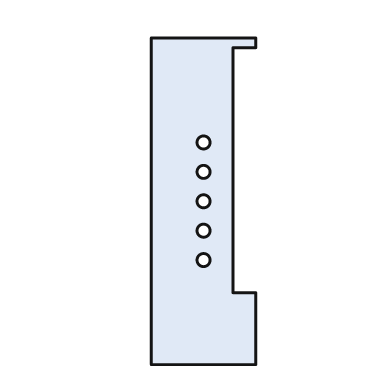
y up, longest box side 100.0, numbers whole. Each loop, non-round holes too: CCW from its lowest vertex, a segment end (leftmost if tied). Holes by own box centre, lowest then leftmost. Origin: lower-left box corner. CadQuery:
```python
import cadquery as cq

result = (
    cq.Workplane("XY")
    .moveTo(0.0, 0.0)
    .lineTo(32.0, 0.0)
    .lineTo(32.0, 22.0)
    .lineTo(25.0, 22.0)
    .lineTo(25.0, 97.0)
    .lineTo(32.0, 97.0)
    .lineTo(32.0, 100.0)
    .lineTo(0.0, 100.0)
    .close()
    .moveTo(16.0, 32.0)
    .circle(2.0)
    .moveTo(16.0, 41.0)
    .circle(2.0)
    .moveTo(16.0, 50.0)
    .circle(2.0)
    .moveTo(16.0, 59.0)
    .circle(2.0)
    .moveTo(16.0, 68.0)
    .circle(2.0)
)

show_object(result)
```